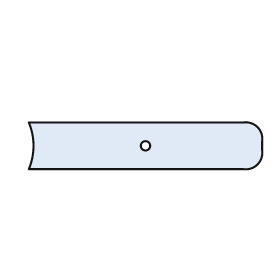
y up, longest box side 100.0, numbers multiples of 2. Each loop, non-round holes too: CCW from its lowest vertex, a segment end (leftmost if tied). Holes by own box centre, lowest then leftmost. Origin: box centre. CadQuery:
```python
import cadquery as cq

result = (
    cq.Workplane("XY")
    .moveTo(-50.0, -10.0)
    .lineTo(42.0, -10.0)
    .threePointArc((48.0, -8.0), (50.0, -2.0))
    .lineTo(50.0, 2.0)
    .threePointArc((48.0, 8.0), (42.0, 10.0))
    .lineTo(-50.0, 10.0)
    .threePointArc((-48.0, 0.0), (-50.0, -10.0))
    .close()
    .moveTo(0.0, 0.0)
    .circle(2.0)
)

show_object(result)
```